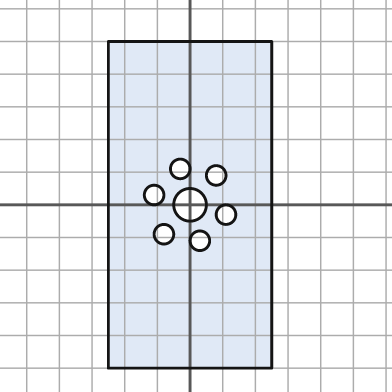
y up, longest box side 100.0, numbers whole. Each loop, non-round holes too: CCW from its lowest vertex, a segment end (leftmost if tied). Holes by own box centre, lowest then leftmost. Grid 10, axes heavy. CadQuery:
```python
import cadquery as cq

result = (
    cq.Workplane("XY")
    .moveTo(-25.0, -50.0)
    .lineTo(25.0, -50.0)
    .lineTo(25.0, 50.0)
    .lineTo(-25.0, 50.0)
    .close()
    .moveTo(3.0, -11.0)
    .circle(3.0)
    .moveTo(-8.0, -9.0)
    .circle(3.0)
    .moveTo(11.0, -3.0)
    .circle(3.0)
    .moveTo(0.0, 0.0)
    .circle(5.0)
    .moveTo(-11.0, 3.0)
    .circle(3.0)
    .moveTo(8.0, 9.0)
    .circle(3.0)
    .moveTo(-3.0, 11.0)
    .circle(3.0)
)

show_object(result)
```